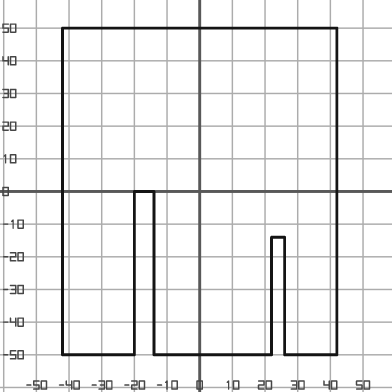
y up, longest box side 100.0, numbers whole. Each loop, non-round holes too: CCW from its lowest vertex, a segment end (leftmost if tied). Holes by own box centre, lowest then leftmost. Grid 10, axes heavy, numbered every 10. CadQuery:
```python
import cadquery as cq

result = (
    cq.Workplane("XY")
    .moveTo(-42.0, -50.0)
    .lineTo(-20.0, -50.0)
    .lineTo(-20.0, 0.0)
    .lineTo(-14.0, 0.0)
    .lineTo(-14.0, -50.0)
    .lineTo(22.0, -50.0)
    .lineTo(22.0, -14.0)
    .lineTo(26.0, -14.0)
    .lineTo(26.0, -50.0)
    .lineTo(42.0, -50.0)
    .lineTo(42.0, 50.0)
    .lineTo(-42.0, 50.0)
    .close()
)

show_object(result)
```